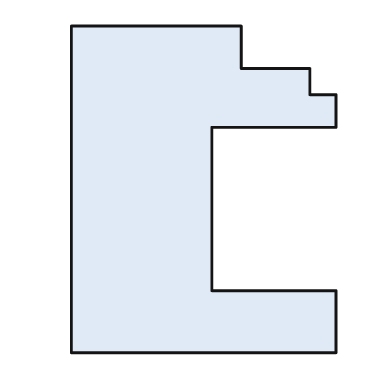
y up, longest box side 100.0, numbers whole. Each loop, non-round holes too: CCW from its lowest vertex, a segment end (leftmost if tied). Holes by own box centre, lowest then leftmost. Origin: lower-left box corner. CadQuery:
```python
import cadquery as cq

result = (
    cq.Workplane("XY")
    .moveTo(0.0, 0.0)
    .lineTo(81.0, 0.0)
    .lineTo(81.0, 19.0)
    .lineTo(43.0, 19.0)
    .lineTo(43.0, 69.0)
    .lineTo(81.0, 69.0)
    .lineTo(81.0, 79.0)
    .lineTo(73.0, 79.0)
    .lineTo(73.0, 87.0)
    .lineTo(52.0, 87.0)
    .lineTo(52.0, 100.0)
    .lineTo(0.0, 100.0)
    .close()
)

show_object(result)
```